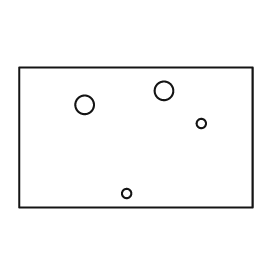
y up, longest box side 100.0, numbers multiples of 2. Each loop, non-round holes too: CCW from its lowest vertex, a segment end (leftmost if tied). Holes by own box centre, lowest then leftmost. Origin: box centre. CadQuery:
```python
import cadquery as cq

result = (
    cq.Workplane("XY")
    .moveTo(-50.0, -30.0)
    .lineTo(50.0, -30.0)
    .lineTo(50.0, 30.0)
    .lineTo(-50.0, 30.0)
    .close()
    .moveTo(-4.0, -24.0)
    .circle(2.0)
    .moveTo(28.0, 6.0)
    .circle(2.0)
    .moveTo(-22.0, 14.0)
    .circle(4.0)
    .moveTo(12.0, 20.0)
    .circle(4.0)
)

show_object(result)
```